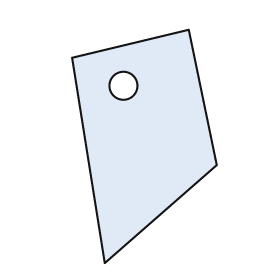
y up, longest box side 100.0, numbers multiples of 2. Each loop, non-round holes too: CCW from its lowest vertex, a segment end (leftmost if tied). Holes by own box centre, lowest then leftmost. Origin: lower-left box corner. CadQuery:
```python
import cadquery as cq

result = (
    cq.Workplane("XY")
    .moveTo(14.0, 0.0)
    .lineTo(62.0, 42.0)
    .lineTo(50.0, 100.0)
    .lineTo(0.0, 88.0)
    .close()
    .moveTo(22.0, 76.0)
    .circle(6.0)
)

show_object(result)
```